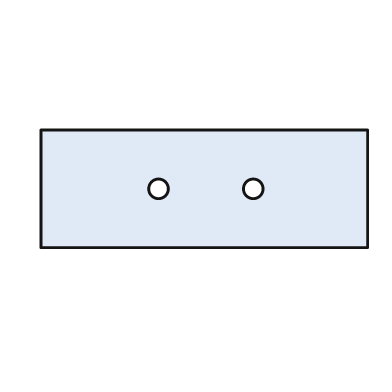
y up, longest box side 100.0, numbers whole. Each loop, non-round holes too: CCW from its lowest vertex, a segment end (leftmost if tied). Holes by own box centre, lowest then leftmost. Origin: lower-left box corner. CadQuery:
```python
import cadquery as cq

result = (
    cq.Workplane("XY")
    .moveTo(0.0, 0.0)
    .lineTo(100.0, 0.0)
    .lineTo(100.0, 36.0)
    .lineTo(0.0, 36.0)
    .close()
    .moveTo(36.0, 18.0)
    .circle(3.0)
    .moveTo(65.0, 18.0)
    .circle(3.0)
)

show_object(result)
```